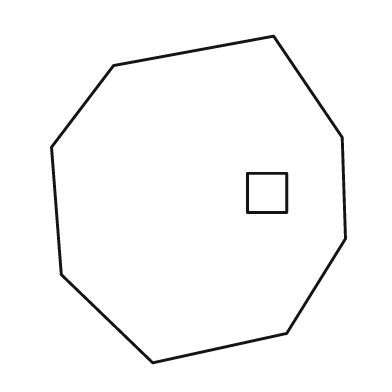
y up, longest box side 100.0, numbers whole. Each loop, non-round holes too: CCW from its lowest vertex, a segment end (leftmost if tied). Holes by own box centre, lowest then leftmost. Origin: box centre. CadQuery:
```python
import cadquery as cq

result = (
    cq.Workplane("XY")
    .moveTo(-14.0, -50.0)
    .lineTo(27.0, -41.0)
    .lineTo(45.0, -12.0)
    .lineTo(44.0, 19.0)
    .lineTo(23.0, 50.0)
    .lineTo(-26.0, 41.0)
    .lineTo(-45.0, 16.0)
    .lineTo(-42.0, -23.0)
    .close()
    .moveTo(15.0, -4.0)
    .lineTo(27.0, -4.0)
    .lineTo(27.0, 8.0)
    .lineTo(15.0, 8.0)
    .close()
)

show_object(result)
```